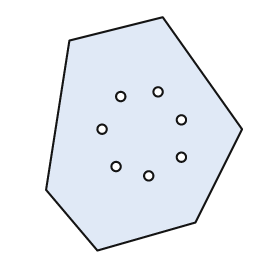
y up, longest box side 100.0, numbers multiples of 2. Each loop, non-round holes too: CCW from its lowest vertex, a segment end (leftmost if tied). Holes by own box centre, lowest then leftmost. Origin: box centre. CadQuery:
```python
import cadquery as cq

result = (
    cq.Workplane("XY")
    .moveTo(-20.0, -50.0)
    .lineTo(22.0, -38.0)
    .lineTo(42.0, 2.0)
    .lineTo(8.0, 50.0)
    .lineTo(-32.0, 40.0)
    .lineTo(-42.0, -24.0)
    .close()
    .moveTo(2.0, -18.0)
    .circle(2.0)
    .moveTo(-12.0, -14.0)
    .circle(2.0)
    .moveTo(16.0, -10.0)
    .circle(2.0)
    .moveTo(-18.0, 2.0)
    .circle(2.0)
    .moveTo(16.0, 6.0)
    .circle(2.0)
    .moveTo(-10.0, 16.0)
    .circle(2.0)
    .moveTo(6.0, 18.0)
    .circle(2.0)
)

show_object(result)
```